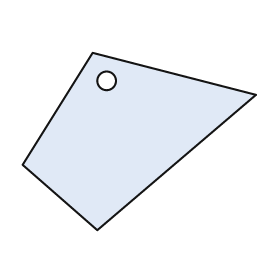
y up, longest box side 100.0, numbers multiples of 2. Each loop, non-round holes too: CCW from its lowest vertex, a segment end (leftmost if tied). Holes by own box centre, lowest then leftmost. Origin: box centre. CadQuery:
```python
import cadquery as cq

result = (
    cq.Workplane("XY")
    .moveTo(-18.0, -38.0)
    .lineTo(50.0, 20.0)
    .lineTo(-20.0, 38.0)
    .lineTo(-50.0, -10.0)
    .close()
    .moveTo(-14.0, 26.0)
    .circle(4.0)
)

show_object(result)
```